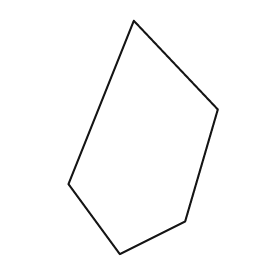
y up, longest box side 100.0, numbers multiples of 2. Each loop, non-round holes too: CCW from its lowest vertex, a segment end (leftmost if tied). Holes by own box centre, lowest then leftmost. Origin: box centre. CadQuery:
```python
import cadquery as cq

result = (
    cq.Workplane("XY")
    .moveTo(-10.0, -50.0)
    .lineTo(18.0, -36.0)
    .lineTo(32.0, 12.0)
    .lineTo(-4.0, 50.0)
    .lineTo(-32.0, -20.0)
    .close()
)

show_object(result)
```